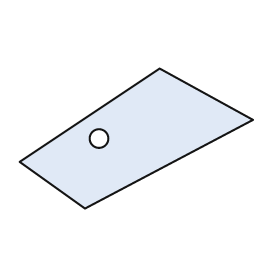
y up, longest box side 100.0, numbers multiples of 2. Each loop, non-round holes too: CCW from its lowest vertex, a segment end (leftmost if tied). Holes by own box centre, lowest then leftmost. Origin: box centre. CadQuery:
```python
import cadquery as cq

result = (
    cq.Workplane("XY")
    .moveTo(-22.0, -30.0)
    .lineTo(50.0, 8.0)
    .lineTo(10.0, 30.0)
    .lineTo(-50.0, -10.0)
    .close()
    .moveTo(-16.0, 0.0)
    .circle(4.0)
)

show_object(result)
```